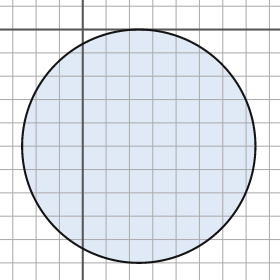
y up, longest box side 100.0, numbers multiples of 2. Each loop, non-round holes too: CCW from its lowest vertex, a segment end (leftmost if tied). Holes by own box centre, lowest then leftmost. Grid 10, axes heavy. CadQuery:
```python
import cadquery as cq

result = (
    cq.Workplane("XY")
    .moveTo(24.0, -50.0)
    .circle(50.0)
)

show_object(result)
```